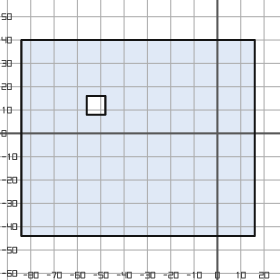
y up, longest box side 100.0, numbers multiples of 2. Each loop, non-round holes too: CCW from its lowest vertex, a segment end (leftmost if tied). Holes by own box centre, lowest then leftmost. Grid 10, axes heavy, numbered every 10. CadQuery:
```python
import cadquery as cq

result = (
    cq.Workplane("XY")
    .moveTo(-84.0, -44.0)
    .lineTo(16.0, -44.0)
    .lineTo(16.0, 40.0)
    .lineTo(-84.0, 40.0)
    .close()
    .moveTo(-56.0, 8.0)
    .lineTo(-48.0, 8.0)
    .lineTo(-48.0, 16.0)
    .lineTo(-56.0, 16.0)
    .close()
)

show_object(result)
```